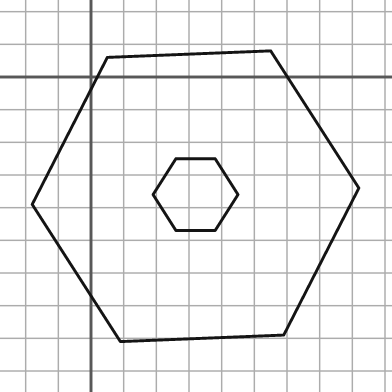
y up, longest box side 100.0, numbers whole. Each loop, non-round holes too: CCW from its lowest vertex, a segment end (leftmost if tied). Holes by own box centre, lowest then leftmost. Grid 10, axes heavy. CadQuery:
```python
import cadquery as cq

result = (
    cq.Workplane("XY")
    .moveTo(9.0, -81.0)
    .lineTo(59.0, -79.0)
    .lineTo(82.0, -34.0)
    .lineTo(55.0, 8.0)
    .lineTo(5.0, 6.0)
    .lineTo(-18.0, -39.0)
    .close()
    .moveTo(26.0, -47.0)
    .lineTo(38.0, -47.0)
    .lineTo(45.0, -36.0)
    .lineTo(38.0, -25.0)
    .lineTo(26.0, -25.0)
    .lineTo(19.0, -36.0)
    .close()
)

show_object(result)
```